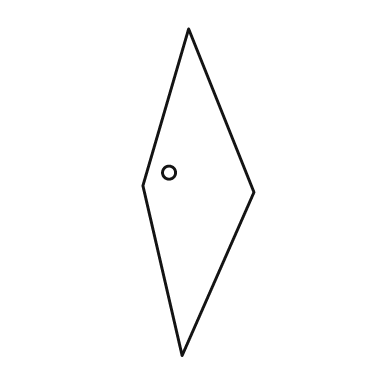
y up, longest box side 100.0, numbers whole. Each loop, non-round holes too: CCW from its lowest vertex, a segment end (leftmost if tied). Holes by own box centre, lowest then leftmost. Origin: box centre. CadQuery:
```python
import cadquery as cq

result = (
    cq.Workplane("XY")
    .moveTo(-5.0, -50.0)
    .lineTo(17.0, 0.0)
    .lineTo(-3.0, 50.0)
    .lineTo(-17.0, 2.0)
    .close()
    .moveTo(-9.0, 6.0)
    .circle(2.0)
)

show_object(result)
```